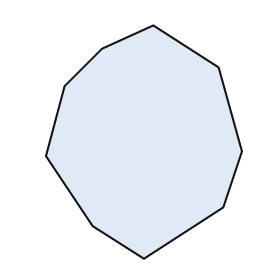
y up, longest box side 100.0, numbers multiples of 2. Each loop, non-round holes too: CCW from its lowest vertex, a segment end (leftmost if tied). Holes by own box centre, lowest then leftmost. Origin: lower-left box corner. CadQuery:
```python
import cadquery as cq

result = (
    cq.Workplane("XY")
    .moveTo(42.0, 0.0)
    .lineTo(76.0, 22.0)
    .lineTo(84.0, 46.0)
    .lineTo(74.0, 82.0)
    .lineTo(46.0, 100.0)
    .lineTo(24.0, 90.0)
    .lineTo(8.0, 74.0)
    .lineTo(0.0, 44.0)
    .lineTo(20.0, 14.0)
    .close()
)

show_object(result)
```